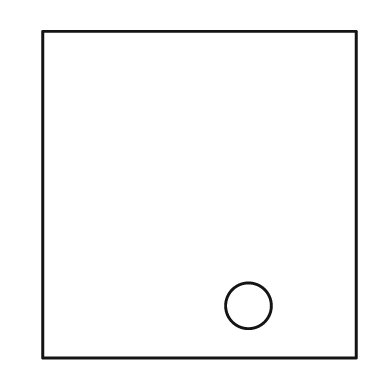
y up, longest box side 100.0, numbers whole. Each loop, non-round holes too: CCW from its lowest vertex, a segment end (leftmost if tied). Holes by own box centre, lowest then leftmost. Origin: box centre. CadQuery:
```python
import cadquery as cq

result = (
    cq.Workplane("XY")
    .moveTo(-48.0, -50.0)
    .lineTo(48.0, -50.0)
    .lineTo(48.0, 50.0)
    .lineTo(-48.0, 50.0)
    .close()
    .moveTo(15.0, -34.0)
    .circle(7.0)
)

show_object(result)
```